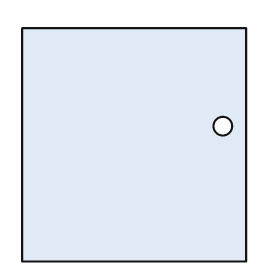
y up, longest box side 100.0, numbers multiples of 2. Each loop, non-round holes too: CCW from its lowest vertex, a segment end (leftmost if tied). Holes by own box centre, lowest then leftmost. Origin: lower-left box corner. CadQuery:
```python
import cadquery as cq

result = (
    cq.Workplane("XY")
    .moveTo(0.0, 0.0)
    .lineTo(96.0, 0.0)
    .lineTo(96.0, 100.0)
    .lineTo(0.0, 100.0)
    .close()
    .moveTo(86.0, 58.0)
    .circle(4.0)
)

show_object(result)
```